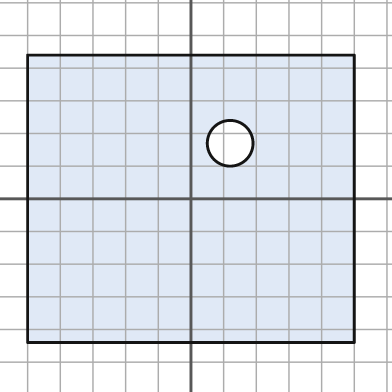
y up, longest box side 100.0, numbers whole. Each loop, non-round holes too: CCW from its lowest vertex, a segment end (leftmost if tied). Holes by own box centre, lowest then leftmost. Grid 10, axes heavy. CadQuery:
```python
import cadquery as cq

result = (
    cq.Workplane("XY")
    .moveTo(-50.0, -44.0)
    .lineTo(50.0, -44.0)
    .lineTo(50.0, 44.0)
    .lineTo(-50.0, 44.0)
    .close()
    .moveTo(12.0, 17.0)
    .circle(7.0)
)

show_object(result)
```